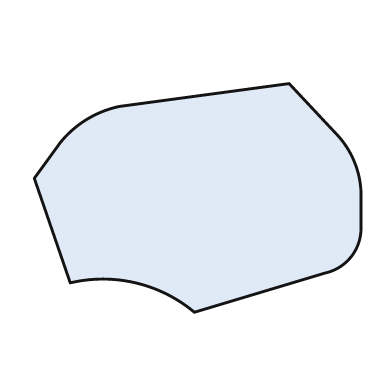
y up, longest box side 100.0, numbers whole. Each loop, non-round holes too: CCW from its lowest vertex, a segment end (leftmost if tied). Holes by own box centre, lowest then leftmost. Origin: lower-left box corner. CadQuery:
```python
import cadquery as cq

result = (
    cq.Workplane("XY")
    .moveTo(49.0, 0.0)
    .lineTo(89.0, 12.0)
    .threePointArc((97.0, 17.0), (100.0, 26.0))
    .lineTo(100.0, 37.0)
    .threePointArc((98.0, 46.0), (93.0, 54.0))
    .lineTo(78.0, 70.0)
    .lineTo(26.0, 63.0)
    .threePointArc((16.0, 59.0), (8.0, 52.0))
    .lineTo(0.0, 41.0)
    .lineTo(11.0, 9.0)
    .threePointArc((31.0, 9.0), (49.0, 0.0))
    .close()
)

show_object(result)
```